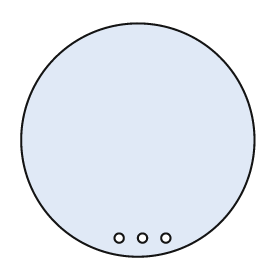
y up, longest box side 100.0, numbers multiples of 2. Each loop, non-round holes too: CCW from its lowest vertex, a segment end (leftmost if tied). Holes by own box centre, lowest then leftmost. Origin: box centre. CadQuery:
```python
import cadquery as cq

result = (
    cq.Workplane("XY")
    .moveTo(0.0, 0.0)
    .circle(50.0)
    .moveTo(-8.0, -42.0)
    .circle(2.0)
    .moveTo(2.0, -42.0)
    .circle(2.0)
    .moveTo(12.0, -42.0)
    .circle(2.0)
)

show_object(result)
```